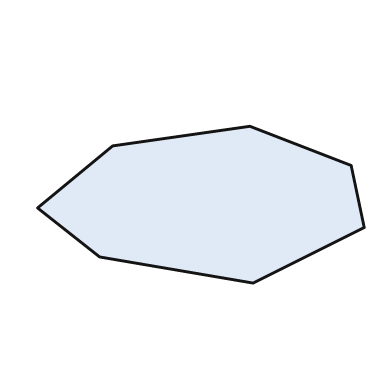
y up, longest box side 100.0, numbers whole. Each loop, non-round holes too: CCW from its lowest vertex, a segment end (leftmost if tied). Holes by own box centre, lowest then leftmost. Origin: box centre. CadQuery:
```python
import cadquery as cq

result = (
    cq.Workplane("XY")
    .moveTo(16.0, -24.0)
    .lineTo(50.0, -7.0)
    .lineTo(46.0, 12.0)
    .lineTo(15.0, 24.0)
    .lineTo(-27.0, 18.0)
    .lineTo(-50.0, -1.0)
    .lineTo(-31.0, -16.0)
    .close()
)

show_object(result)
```